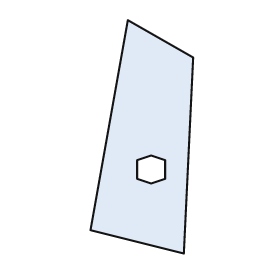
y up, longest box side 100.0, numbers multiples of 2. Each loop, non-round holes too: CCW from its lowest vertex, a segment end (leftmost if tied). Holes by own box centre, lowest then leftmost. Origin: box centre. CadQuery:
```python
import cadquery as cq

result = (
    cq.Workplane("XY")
    .moveTo(18.0, -50.0)
    .lineTo(22.0, 34.0)
    .lineTo(-6.0, 50.0)
    .lineTo(-22.0, -40.0)
    .close()
    .moveTo(4.0, -20.0)
    .lineTo(10.0, -18.0)
    .lineTo(10.0, -10.0)
    .lineTo(4.0, -8.0)
    .lineTo(-2.0, -10.0)
    .lineTo(-2.0, -18.0)
    .close()
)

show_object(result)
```